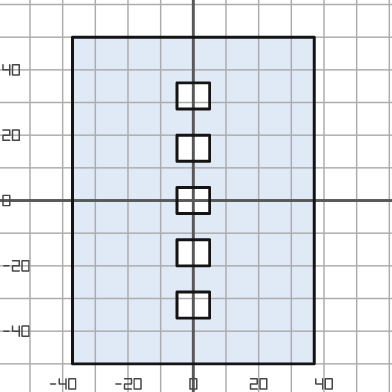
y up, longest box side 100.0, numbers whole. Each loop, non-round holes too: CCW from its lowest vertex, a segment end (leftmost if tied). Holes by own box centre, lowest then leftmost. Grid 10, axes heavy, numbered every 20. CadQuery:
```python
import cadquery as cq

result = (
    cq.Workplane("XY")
    .moveTo(-37.0, -50.0)
    .lineTo(37.0, -50.0)
    .lineTo(37.0, 50.0)
    .lineTo(-37.0, 50.0)
    .close()
    .moveTo(-5.0, -36.0)
    .lineTo(5.0, -36.0)
    .lineTo(5.0, -28.0)
    .lineTo(-5.0, -28.0)
    .close()
    .moveTo(-5.0, -20.0)
    .lineTo(5.0, -20.0)
    .lineTo(5.0, -12.0)
    .lineTo(-5.0, -12.0)
    .close()
    .moveTo(-5.0, -4.0)
    .lineTo(5.0, -4.0)
    .lineTo(5.0, 4.0)
    .lineTo(-5.0, 4.0)
    .close()
    .moveTo(-5.0, 12.0)
    .lineTo(5.0, 12.0)
    .lineTo(5.0, 20.0)
    .lineTo(-5.0, 20.0)
    .close()
    .moveTo(-5.0, 28.0)
    .lineTo(5.0, 28.0)
    .lineTo(5.0, 36.0)
    .lineTo(-5.0, 36.0)
    .close()
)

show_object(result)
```